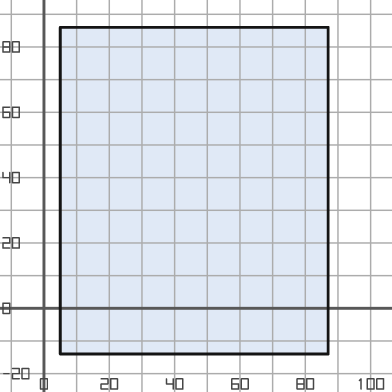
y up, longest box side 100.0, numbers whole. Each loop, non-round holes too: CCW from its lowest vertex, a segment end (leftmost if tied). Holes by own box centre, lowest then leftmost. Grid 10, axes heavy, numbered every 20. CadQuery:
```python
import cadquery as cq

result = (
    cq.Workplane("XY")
    .moveTo(5.0, -14.0)
    .lineTo(87.0, -14.0)
    .lineTo(87.0, 86.0)
    .lineTo(5.0, 86.0)
    .close()
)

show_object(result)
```